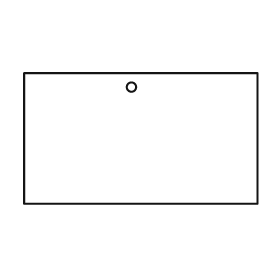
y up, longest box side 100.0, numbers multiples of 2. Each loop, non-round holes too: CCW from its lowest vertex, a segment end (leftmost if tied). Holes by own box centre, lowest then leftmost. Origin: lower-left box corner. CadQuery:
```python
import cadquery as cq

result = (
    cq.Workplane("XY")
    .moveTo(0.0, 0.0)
    .lineTo(100.0, 0.0)
    .lineTo(100.0, 56.0)
    .lineTo(0.0, 56.0)
    .close()
    .moveTo(46.0, 50.0)
    .circle(2.0)
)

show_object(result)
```